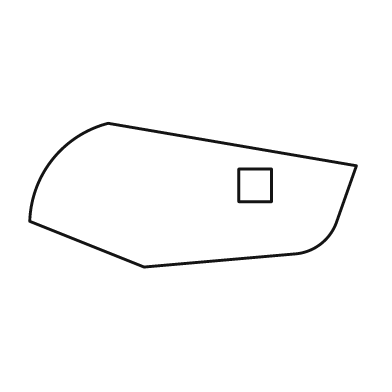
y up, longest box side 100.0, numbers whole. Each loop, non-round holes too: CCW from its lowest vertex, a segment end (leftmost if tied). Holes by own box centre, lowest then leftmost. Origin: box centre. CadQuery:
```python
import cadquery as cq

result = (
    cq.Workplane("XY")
    .moveTo(-15.0, -22.0)
    .lineTo(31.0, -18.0)
    .threePointArc((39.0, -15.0), (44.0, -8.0))
    .lineTo(50.0, 9.0)
    .lineTo(-26.0, 22.0)
    .threePointArc((-43.0, 11.0), (-50.0, -8.0))
    .close()
    .moveTo(14.0, -2.0)
    .lineTo(24.0, -2.0)
    .lineTo(24.0, 8.0)
    .lineTo(14.0, 8.0)
    .close()
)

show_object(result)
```